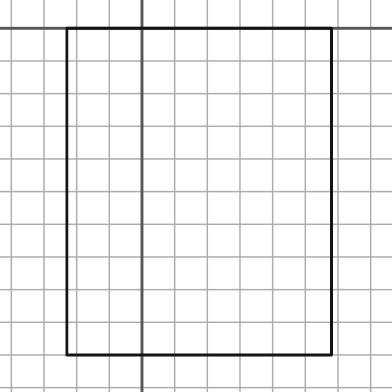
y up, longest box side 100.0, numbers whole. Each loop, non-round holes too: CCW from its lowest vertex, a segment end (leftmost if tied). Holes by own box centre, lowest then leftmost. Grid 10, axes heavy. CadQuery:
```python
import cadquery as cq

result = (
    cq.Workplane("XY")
    .moveTo(-23.0, -100.0)
    .lineTo(58.0, -100.0)
    .lineTo(58.0, 0.0)
    .lineTo(-23.0, 0.0)
    .close()
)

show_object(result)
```